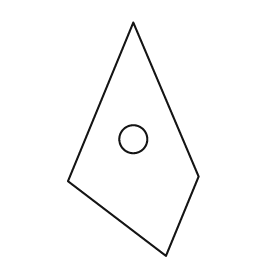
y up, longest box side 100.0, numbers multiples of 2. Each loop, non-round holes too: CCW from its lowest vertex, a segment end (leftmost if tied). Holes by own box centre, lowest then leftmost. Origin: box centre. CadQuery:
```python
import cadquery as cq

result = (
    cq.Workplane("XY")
    .moveTo(14.0, -50.0)
    .lineTo(28.0, -16.0)
    .lineTo(0.0, 50.0)
    .lineTo(-28.0, -18.0)
    .close()
    .moveTo(0.0, 0.0)
    .circle(6.0)
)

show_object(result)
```